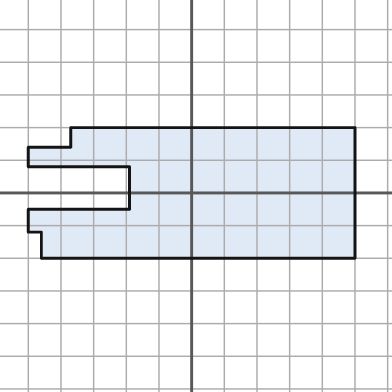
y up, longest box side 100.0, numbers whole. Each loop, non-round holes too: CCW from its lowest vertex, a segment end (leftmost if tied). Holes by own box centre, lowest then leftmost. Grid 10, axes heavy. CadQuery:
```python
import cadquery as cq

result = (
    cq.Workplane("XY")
    .moveTo(-46.0, -20.0)
    .lineTo(50.0, -20.0)
    .lineTo(50.0, 20.0)
    .lineTo(-37.0, 20.0)
    .lineTo(-37.0, 14.0)
    .lineTo(-50.0, 14.0)
    .lineTo(-50.0, 8.0)
    .lineTo(-19.0, 8.0)
    .lineTo(-19.0, -5.0)
    .lineTo(-50.0, -5.0)
    .lineTo(-50.0, -12.0)
    .lineTo(-46.0, -12.0)
    .close()
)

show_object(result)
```